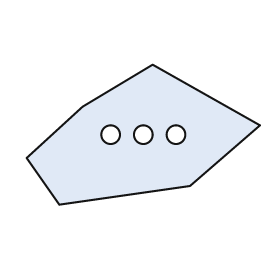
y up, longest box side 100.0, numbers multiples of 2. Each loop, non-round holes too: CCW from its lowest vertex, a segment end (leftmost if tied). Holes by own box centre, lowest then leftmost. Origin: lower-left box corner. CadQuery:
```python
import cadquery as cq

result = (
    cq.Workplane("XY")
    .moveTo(14.0, 0.0)
    .lineTo(70.0, 8.0)
    .lineTo(100.0, 34.0)
    .lineTo(54.0, 60.0)
    .lineTo(24.0, 42.0)
    .lineTo(0.0, 20.0)
    .close()
    .moveTo(36.0, 30.0)
    .circle(4.0)
    .moveTo(50.0, 30.0)
    .circle(4.0)
    .moveTo(64.0, 30.0)
    .circle(4.0)
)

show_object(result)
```